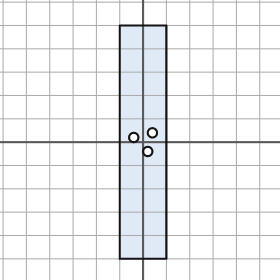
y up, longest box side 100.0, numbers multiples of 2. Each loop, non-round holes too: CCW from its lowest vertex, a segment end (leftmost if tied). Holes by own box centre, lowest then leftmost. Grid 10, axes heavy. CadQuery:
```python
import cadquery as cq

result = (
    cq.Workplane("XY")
    .moveTo(-10.0, -50.0)
    .lineTo(10.0, -50.0)
    .lineTo(10.0, 50.0)
    .lineTo(-10.0, 50.0)
    .close()
    .moveTo(2.0, -4.0)
    .circle(2.0)
    .moveTo(-4.0, 2.0)
    .circle(2.0)
    .moveTo(4.0, 4.0)
    .circle(2.0)
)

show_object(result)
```